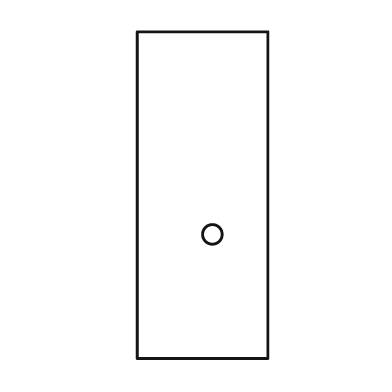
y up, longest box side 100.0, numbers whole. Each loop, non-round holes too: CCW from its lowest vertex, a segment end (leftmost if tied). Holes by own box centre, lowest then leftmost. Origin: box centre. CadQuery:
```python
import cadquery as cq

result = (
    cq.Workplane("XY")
    .moveTo(-20.0, -50.0)
    .lineTo(20.0, -50.0)
    .lineTo(20.0, 50.0)
    .lineTo(-20.0, 50.0)
    .close()
    .moveTo(3.0, -12.0)
    .circle(3.0)
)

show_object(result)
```